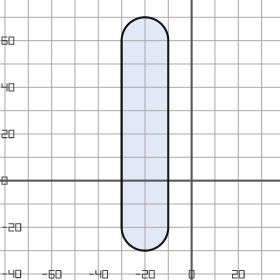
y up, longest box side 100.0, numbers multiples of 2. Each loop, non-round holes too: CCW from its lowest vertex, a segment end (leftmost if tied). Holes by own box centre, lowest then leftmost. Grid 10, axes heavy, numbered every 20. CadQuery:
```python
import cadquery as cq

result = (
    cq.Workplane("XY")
    .moveTo(-30.0, -20.0)
    .threePointArc((-20.0, -30.0), (-10.0, -20.0))
    .lineTo(-10.0, 60.0)
    .threePointArc((-20.0, 70.0), (-30.0, 60.0))
    .close()
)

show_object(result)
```